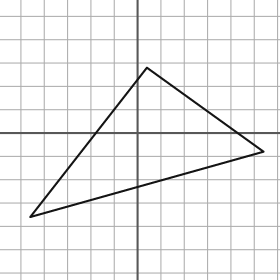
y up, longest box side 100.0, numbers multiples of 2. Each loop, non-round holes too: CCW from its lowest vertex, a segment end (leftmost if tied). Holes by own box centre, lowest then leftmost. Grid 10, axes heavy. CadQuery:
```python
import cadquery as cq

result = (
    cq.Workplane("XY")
    .moveTo(-46.0, -36.0)
    .lineTo(54.0, -8.0)
    .lineTo(4.0, 28.0)
    .close()
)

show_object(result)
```